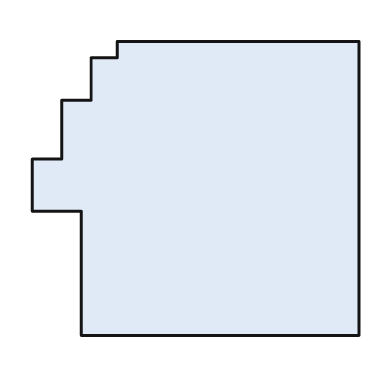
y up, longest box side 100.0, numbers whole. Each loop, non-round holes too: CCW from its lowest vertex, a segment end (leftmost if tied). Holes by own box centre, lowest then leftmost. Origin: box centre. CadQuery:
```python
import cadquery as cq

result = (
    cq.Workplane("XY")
    .moveTo(-35.0, -45.0)
    .lineTo(50.0, -45.0)
    .lineTo(50.0, 45.0)
    .lineTo(-24.0, 45.0)
    .lineTo(-24.0, 40.0)
    .lineTo(-32.0, 40.0)
    .lineTo(-32.0, 27.0)
    .lineTo(-41.0, 27.0)
    .lineTo(-41.0, 9.0)
    .lineTo(-50.0, 9.0)
    .lineTo(-50.0, -7.0)
    .lineTo(-35.0, -7.0)
    .close()
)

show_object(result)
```